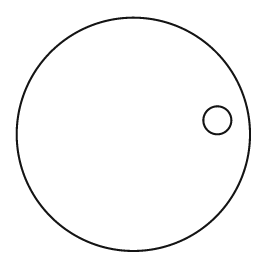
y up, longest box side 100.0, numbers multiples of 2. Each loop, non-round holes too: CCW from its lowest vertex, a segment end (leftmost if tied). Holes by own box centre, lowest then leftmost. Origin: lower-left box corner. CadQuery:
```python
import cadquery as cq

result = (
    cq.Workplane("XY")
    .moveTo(50.0, 50.0)
    .circle(50.0)
    .moveTo(86.0, 56.0)
    .circle(6.0)
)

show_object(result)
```